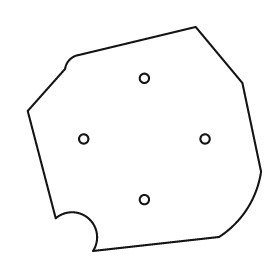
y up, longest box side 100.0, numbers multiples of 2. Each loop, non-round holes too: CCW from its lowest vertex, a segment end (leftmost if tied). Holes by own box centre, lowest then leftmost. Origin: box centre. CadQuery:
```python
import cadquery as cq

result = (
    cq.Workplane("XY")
    .moveTo(-22.0, -48.0)
    .lineTo(32.0, -42.0)
    .threePointArc((44.0, -30.0), (50.0, -14.0))
    .lineTo(42.0, 24.0)
    .lineTo(22.0, 48.0)
    .lineTo(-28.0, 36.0)
    .threePointArc((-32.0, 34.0), (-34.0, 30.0))
    .lineTo(-50.0, 12.0)
    .lineTo(-38.0, -34.0)
    .threePointArc((-24.0, -34.0), (-22.0, -48.0))
    .close()
    .moveTo(0.0, -26.0)
    .circle(2.0)
    .moveTo(-26.0, 0.0)
    .circle(2.0)
    .moveTo(26.0, 0.0)
    .circle(2.0)
    .moveTo(0.0, 26.0)
    .circle(2.0)
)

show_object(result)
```